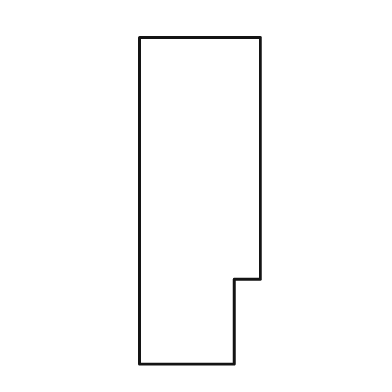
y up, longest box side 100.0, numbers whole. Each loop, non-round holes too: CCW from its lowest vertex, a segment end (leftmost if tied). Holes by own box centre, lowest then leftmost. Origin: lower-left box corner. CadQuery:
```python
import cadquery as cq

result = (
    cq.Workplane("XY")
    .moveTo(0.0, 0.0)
    .lineTo(29.0, 0.0)
    .lineTo(29.0, 26.0)
    .lineTo(37.0, 26.0)
    .lineTo(37.0, 100.0)
    .lineTo(0.0, 100.0)
    .close()
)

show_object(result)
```